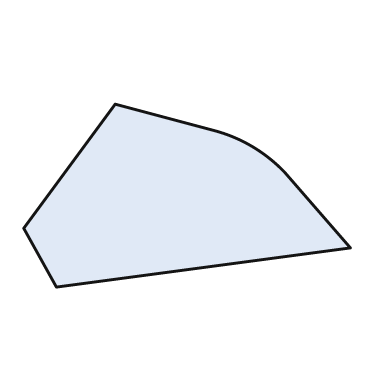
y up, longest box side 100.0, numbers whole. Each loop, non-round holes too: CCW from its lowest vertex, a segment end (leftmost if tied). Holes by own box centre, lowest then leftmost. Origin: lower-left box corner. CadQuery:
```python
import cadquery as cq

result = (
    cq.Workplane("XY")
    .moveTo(10.0, 0.0)
    .lineTo(100.0, 12.0)
    .lineTo(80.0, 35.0)
    .threePointArc((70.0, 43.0), (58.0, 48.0))
    .lineTo(28.0, 56.0)
    .lineTo(0.0, 18.0)
    .close()
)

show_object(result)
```